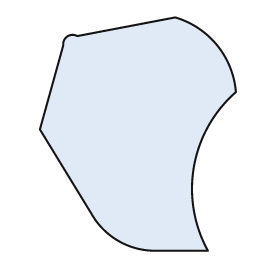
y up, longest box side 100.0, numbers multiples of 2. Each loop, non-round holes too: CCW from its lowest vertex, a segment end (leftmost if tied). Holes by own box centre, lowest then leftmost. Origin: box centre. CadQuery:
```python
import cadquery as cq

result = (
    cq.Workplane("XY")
    .moveTo(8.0, -50.0)
    .lineTo(30.0, -50.0)
    .threePointArc((24.0, -14.0), (42.0, 18.0))
    .threePointArc((34.0, 38.0), (16.0, 50.0))
    .lineTo(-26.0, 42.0)
    .threePointArc((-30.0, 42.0), (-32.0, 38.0))
    .lineTo(-42.0, 2.0)
    .lineTo(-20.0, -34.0)
    .threePointArc((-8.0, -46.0), (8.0, -50.0))
    .close()
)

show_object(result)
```